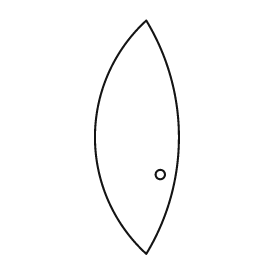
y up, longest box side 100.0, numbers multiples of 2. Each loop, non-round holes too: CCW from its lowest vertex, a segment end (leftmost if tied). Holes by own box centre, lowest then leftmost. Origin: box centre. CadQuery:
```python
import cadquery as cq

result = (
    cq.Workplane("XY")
    .moveTo(4.0, -50.0)
    .threePointArc((18.0, 0.0), (4.0, 50.0))
    .threePointArc((-18.0, 0.0), (4.0, -50.0))
    .close()
    .moveTo(10.0, -16.0)
    .circle(2.0)
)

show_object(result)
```